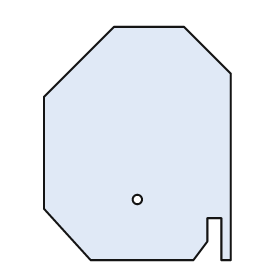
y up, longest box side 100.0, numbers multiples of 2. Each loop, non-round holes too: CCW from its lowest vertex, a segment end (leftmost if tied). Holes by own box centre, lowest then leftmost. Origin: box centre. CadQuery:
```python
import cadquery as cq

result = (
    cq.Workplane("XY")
    .moveTo(-20.0, -50.0)
    .lineTo(24.0, -50.0)
    .lineTo(30.0, -42.0)
    .lineTo(30.0, -32.0)
    .lineTo(36.0, -32.0)
    .lineTo(36.0, -50.0)
    .lineTo(40.0, -50.0)
    .lineTo(40.0, 30.0)
    .lineTo(20.0, 50.0)
    .lineTo(-10.0, 50.0)
    .lineTo(-40.0, 20.0)
    .lineTo(-40.0, -28.0)
    .close()
    .moveTo(0.0, -24.0)
    .circle(2.0)
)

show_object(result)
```